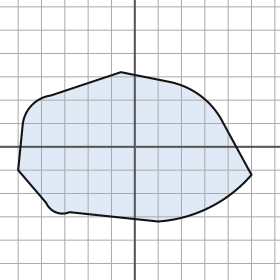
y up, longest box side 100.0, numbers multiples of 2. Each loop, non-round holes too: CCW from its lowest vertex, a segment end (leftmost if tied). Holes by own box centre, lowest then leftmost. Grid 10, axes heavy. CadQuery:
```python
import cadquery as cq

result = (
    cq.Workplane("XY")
    .moveTo(10.0, -32.0)
    .threePointArc((32.0, -26.0), (50.0, -12.0))
    .lineTo(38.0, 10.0)
    .threePointArc((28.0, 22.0), (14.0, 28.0))
    .lineTo(-6.0, 32.0)
    .lineTo(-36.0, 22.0)
    .threePointArc((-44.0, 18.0), (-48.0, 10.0))
    .lineTo(-50.0, -10.0)
    .lineTo(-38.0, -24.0)
    .threePointArc((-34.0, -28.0), (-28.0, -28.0))
    .close()
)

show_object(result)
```